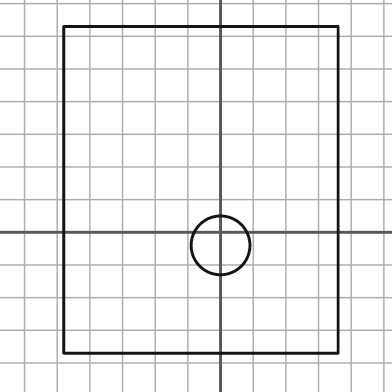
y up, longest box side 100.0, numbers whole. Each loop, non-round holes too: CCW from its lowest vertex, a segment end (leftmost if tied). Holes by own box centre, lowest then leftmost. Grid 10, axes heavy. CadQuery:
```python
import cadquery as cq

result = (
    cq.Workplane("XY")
    .moveTo(-48.0, -37.0)
    .lineTo(36.0, -37.0)
    .lineTo(36.0, 63.0)
    .lineTo(-48.0, 63.0)
    .close()
    .moveTo(0.0, -4.0)
    .circle(9.0)
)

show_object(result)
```